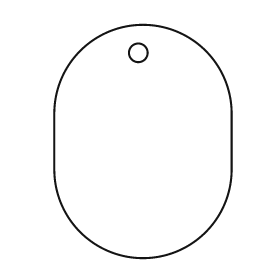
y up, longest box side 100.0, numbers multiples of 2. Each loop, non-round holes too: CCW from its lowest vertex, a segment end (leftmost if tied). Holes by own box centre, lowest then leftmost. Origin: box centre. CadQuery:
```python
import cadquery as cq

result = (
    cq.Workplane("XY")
    .moveTo(-38.0, -12.0)
    .threePointArc((0.0, -50.0), (38.0, -12.0))
    .lineTo(38.0, 12.0)
    .threePointArc((0.0, 50.0), (-38.0, 12.0))
    .close()
    .moveTo(-2.0, 38.0)
    .circle(4.0)
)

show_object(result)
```